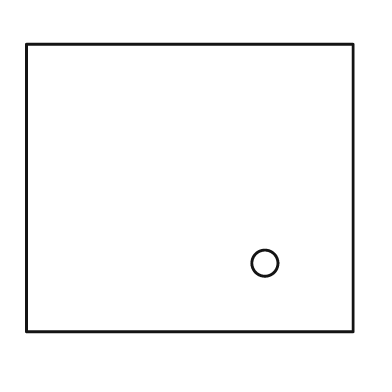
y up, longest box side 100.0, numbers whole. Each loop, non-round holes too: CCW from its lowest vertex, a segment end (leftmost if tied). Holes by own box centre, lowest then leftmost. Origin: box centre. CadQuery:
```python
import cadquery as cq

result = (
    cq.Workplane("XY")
    .moveTo(-50.0, -44.0)
    .lineTo(50.0, -44.0)
    .lineTo(50.0, 44.0)
    .lineTo(-50.0, 44.0)
    .close()
    .moveTo(23.0, -23.0)
    .circle(4.0)
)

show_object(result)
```